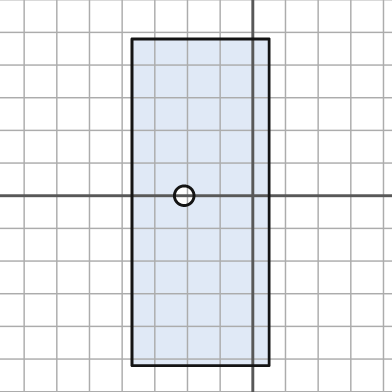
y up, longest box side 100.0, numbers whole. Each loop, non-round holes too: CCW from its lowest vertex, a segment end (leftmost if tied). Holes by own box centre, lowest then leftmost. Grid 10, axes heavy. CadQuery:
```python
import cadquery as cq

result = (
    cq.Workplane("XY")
    .moveTo(-37.0, -52.0)
    .lineTo(5.0, -52.0)
    .lineTo(5.0, 48.0)
    .lineTo(-37.0, 48.0)
    .close()
    .moveTo(-21.0, 0.0)
    .circle(3.0)
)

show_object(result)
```